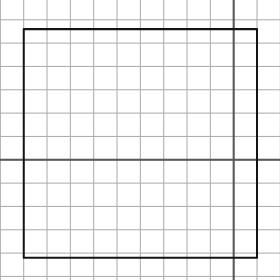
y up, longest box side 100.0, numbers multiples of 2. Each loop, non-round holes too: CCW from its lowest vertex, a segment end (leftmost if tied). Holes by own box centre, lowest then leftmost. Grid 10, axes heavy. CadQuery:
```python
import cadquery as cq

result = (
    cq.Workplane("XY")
    .moveTo(-90.0, -42.0)
    .lineTo(10.0, -42.0)
    .lineTo(10.0, 56.0)
    .lineTo(-90.0, 56.0)
    .close()
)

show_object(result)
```